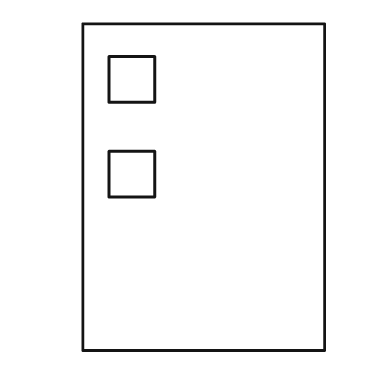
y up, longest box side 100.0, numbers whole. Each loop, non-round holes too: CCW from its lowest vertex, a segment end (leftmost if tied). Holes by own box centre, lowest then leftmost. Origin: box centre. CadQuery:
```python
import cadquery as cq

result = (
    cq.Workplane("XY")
    .moveTo(-37.0, -50.0)
    .lineTo(37.0, -50.0)
    .lineTo(37.0, 50.0)
    .lineTo(-37.0, 50.0)
    .close()
    .moveTo(-29.0, -3.0)
    .lineTo(-15.0, -3.0)
    .lineTo(-15.0, 11.0)
    .lineTo(-29.0, 11.0)
    .close()
    .moveTo(-29.0, 26.0)
    .lineTo(-15.0, 26.0)
    .lineTo(-15.0, 40.0)
    .lineTo(-29.0, 40.0)
    .close()
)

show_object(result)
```